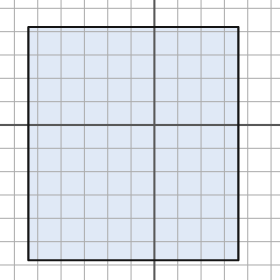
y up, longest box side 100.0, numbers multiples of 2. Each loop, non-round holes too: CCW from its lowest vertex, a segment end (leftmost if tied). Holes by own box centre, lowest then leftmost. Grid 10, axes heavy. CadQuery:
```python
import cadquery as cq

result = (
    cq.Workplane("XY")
    .moveTo(-54.0, -58.0)
    .lineTo(36.0, -58.0)
    .lineTo(36.0, 42.0)
    .lineTo(-54.0, 42.0)
    .close()
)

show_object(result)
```